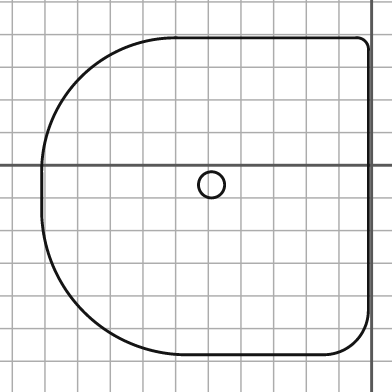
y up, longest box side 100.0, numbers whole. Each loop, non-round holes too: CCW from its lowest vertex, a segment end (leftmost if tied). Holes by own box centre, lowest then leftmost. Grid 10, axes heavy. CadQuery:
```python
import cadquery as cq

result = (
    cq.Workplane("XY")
    .moveTo(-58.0, -58.0)
    .lineTo(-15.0, -58.0)
    .threePointArc((-5.0, -54.0), (-1.0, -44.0))
    .lineTo(-1.0, 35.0)
    .threePointArc((-2.0, 38.0), (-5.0, 39.0))
    .lineTo(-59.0, 39.0)
    .threePointArc((-89.0, 27.0), (-101.0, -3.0))
    .lineTo(-101.0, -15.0)
    .threePointArc((-88.0, -45.0), (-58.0, -58.0))
    .close()
    .moveTo(-49.0, -6.0)
    .circle(4.0)
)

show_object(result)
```